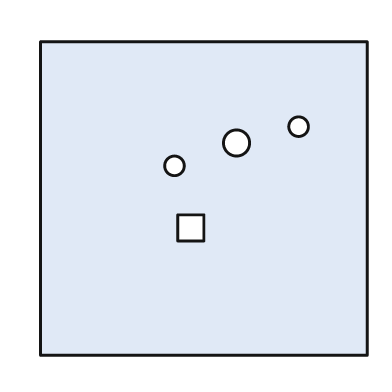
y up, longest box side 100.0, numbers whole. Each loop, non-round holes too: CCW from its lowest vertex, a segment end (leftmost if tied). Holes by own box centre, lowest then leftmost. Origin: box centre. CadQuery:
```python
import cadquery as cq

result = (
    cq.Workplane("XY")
    .moveTo(-50.0, -48.0)
    .lineTo(50.0, -48.0)
    .lineTo(50.0, 48.0)
    .lineTo(-50.0, 48.0)
    .close()
    .moveTo(-8.0, -13.0)
    .lineTo(0.0, -13.0)
    .lineTo(0.0, -5.0)
    .lineTo(-8.0, -5.0)
    .close()
    .moveTo(-9.0, 10.0)
    .circle(3.0)
    .moveTo(10.0, 17.0)
    .circle(4.0)
    .moveTo(29.0, 22.0)
    .circle(3.0)
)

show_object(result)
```